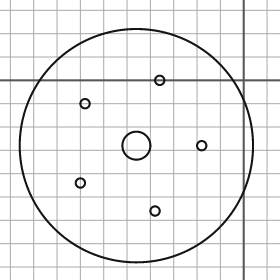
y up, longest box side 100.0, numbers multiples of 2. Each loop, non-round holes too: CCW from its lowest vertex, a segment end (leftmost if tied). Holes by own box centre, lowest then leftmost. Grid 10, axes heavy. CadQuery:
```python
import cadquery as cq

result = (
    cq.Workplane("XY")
    .moveTo(-46.0, -28.0)
    .circle(50.0)
    .moveTo(-38.0, -56.0)
    .circle(2.0)
    .moveTo(-70.0, -44.0)
    .circle(2.0)
    .moveTo(-46.0, -28.0)
    .circle(6.0)
    .moveTo(-18.0, -28.0)
    .circle(2.0)
    .moveTo(-68.0, -10.0)
    .circle(2.0)
    .moveTo(-36.0, 0.0)
    .circle(2.0)
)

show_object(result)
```